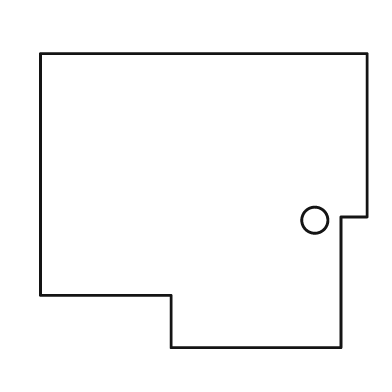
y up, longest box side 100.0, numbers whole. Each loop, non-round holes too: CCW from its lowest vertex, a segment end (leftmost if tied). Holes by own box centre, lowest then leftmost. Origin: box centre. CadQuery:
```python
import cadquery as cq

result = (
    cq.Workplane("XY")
    .moveTo(-10.0, -45.0)
    .lineTo(42.0, -45.0)
    .lineTo(42.0, -5.0)
    .lineTo(50.0, -5.0)
    .lineTo(50.0, 45.0)
    .lineTo(-50.0, 45.0)
    .lineTo(-50.0, -29.0)
    .lineTo(-10.0, -29.0)
    .close()
    .moveTo(34.0, -6.0)
    .circle(4.0)
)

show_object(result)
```